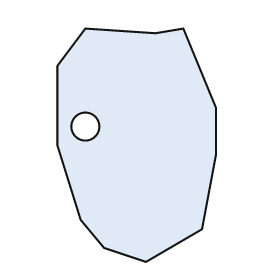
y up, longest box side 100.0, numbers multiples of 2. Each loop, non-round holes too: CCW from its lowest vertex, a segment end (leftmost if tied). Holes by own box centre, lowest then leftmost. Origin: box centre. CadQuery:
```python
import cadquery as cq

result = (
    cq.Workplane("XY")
    .moveTo(4.0, -50.0)
    .lineTo(28.0, -36.0)
    .lineTo(34.0, -4.0)
    .lineTo(34.0, 16.0)
    .lineTo(20.0, 50.0)
    .lineTo(8.0, 48.0)
    .lineTo(-22.0, 50.0)
    .lineTo(-34.0, 34.0)
    .lineTo(-34.0, 0.0)
    .lineTo(-24.0, -32.0)
    .lineTo(-14.0, -44.0)
    .close()
    .moveTo(-22.0, 8.0)
    .circle(6.0)
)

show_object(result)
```